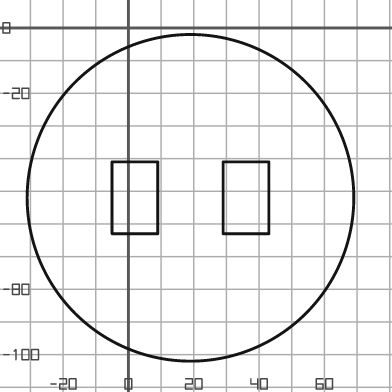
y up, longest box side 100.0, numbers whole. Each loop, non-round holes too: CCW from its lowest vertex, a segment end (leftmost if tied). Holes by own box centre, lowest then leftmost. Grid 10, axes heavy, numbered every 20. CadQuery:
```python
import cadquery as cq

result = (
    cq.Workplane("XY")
    .moveTo(19.0, -52.0)
    .circle(50.0)
    .moveTo(-5.0, -63.0)
    .lineTo(9.0, -63.0)
    .lineTo(9.0, -41.0)
    .lineTo(-5.0, -41.0)
    .close()
    .moveTo(29.0, -63.0)
    .lineTo(43.0, -63.0)
    .lineTo(43.0, -41.0)
    .lineTo(29.0, -41.0)
    .close()
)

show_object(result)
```